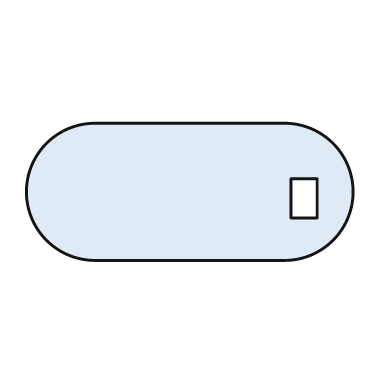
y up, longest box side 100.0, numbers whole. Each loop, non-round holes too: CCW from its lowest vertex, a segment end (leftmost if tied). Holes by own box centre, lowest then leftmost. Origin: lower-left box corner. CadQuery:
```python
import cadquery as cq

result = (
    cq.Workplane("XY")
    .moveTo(21.0, 0.0)
    .lineTo(79.0, 0.0)
    .threePointArc((100.0, 21.0), (79.0, 42.0))
    .lineTo(21.0, 42.0)
    .threePointArc((0.0, 21.0), (21.0, 0.0))
    .close()
    .moveTo(81.0, 13.0)
    .lineTo(89.0, 13.0)
    .lineTo(89.0, 25.0)
    .lineTo(81.0, 25.0)
    .close()
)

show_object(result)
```